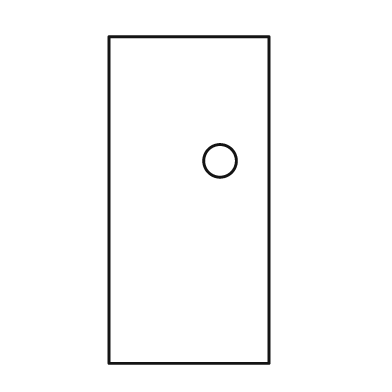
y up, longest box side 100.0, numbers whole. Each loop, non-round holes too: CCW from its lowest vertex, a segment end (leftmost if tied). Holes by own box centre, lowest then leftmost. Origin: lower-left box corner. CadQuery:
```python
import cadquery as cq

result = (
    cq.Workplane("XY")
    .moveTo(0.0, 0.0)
    .lineTo(49.0, 0.0)
    .lineTo(49.0, 100.0)
    .lineTo(0.0, 100.0)
    .close()
    .moveTo(34.0, 62.0)
    .circle(5.0)
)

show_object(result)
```